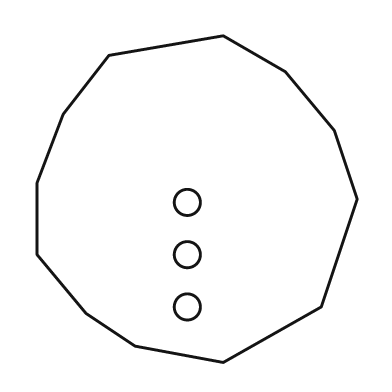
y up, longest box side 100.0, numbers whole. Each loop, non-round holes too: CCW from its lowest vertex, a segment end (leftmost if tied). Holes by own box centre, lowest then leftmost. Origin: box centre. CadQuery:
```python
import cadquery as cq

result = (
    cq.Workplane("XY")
    .moveTo(8.0, -50.0)
    .lineTo(38.0, -33.0)
    .lineTo(49.0, 0.0)
    .lineTo(42.0, 21.0)
    .lineTo(27.0, 39.0)
    .lineTo(8.0, 50.0)
    .lineTo(-27.0, 44.0)
    .lineTo(-41.0, 26.0)
    .lineTo(-49.0, 5.0)
    .lineTo(-49.0, -17.0)
    .lineTo(-34.0, -35.0)
    .lineTo(-19.0, -45.0)
    .close()
    .moveTo(-3.0, -33.0)
    .circle(4.0)
    .moveTo(-3.0, -17.0)
    .circle(4.0)
    .moveTo(-3.0, -1.0)
    .circle(4.0)
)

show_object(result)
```